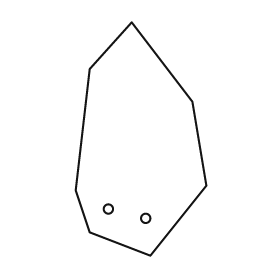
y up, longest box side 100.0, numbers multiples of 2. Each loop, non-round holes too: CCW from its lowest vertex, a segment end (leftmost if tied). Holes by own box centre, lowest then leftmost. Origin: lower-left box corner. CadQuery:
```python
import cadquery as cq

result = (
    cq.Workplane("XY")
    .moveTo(32.0, 0.0)
    .lineTo(56.0, 30.0)
    .lineTo(50.0, 66.0)
    .lineTo(24.0, 100.0)
    .lineTo(6.0, 80.0)
    .lineTo(0.0, 28.0)
    .lineTo(6.0, 10.0)
    .close()
    .moveTo(30.0, 16.0)
    .circle(2.0)
    .moveTo(14.0, 20.0)
    .circle(2.0)
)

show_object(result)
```